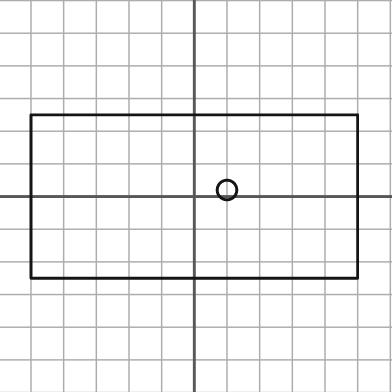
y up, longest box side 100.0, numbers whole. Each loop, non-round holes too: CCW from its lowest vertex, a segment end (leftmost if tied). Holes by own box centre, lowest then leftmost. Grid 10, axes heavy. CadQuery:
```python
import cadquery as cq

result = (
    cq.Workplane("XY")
    .moveTo(-50.0, -25.0)
    .lineTo(50.0, -25.0)
    .lineTo(50.0, 25.0)
    .lineTo(-50.0, 25.0)
    .close()
    .moveTo(10.0, 2.0)
    .circle(3.0)
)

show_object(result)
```